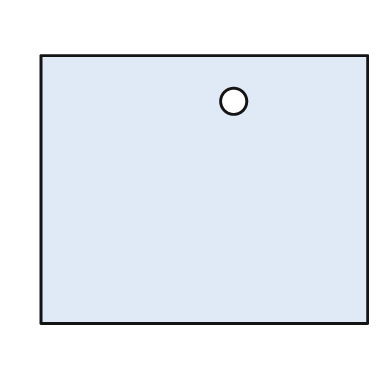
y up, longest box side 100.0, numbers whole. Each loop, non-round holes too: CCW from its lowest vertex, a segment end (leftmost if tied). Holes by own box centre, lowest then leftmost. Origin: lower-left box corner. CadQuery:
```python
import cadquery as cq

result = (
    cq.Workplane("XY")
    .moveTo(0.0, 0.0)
    .lineTo(100.0, 0.0)
    .lineTo(100.0, 82.0)
    .lineTo(0.0, 82.0)
    .close()
    .moveTo(59.0, 68.0)
    .circle(4.0)
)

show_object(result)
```